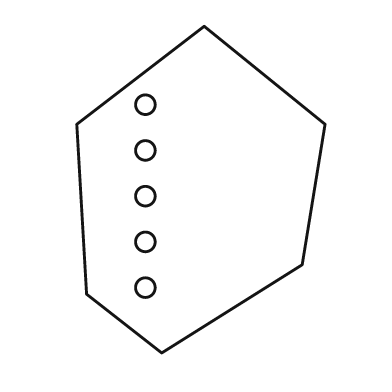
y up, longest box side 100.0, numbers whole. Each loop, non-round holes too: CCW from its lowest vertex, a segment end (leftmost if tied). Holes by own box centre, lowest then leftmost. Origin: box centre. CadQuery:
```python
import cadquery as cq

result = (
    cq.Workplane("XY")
    .moveTo(-12.0, -50.0)
    .lineTo(31.0, -23.0)
    .lineTo(38.0, 20.0)
    .lineTo(1.0, 50.0)
    .lineTo(-38.0, 20.0)
    .lineTo(-35.0, -32.0)
    .close()
    .moveTo(-17.0, -30.0)
    .circle(3.0)
    .moveTo(-17.0, -16.0)
    .circle(3.0)
    .moveTo(-17.0, -2.0)
    .circle(3.0)
    .moveTo(-17.0, 12.0)
    .circle(3.0)
    .moveTo(-17.0, 26.0)
    .circle(3.0)
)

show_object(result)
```